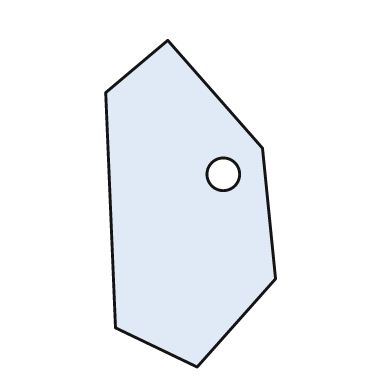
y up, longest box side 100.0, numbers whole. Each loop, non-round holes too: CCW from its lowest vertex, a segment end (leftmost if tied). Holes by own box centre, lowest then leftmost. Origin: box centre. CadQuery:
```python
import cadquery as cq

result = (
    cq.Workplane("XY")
    .moveTo(2.0, -50.0)
    .lineTo(26.0, -23.0)
    .lineTo(22.0, 17.0)
    .lineTo(-7.0, 50.0)
    .lineTo(-26.0, 34.0)
    .lineTo(-23.0, -38.0)
    .close()
    .moveTo(10.0, 9.0)
    .circle(5.0)
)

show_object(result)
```